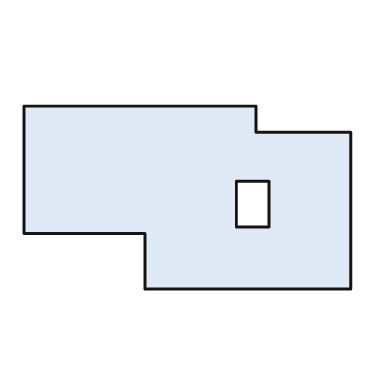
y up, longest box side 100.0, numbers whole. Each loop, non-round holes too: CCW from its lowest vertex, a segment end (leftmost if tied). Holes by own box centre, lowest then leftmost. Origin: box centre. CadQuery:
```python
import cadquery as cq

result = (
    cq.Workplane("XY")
    .moveTo(-13.0, -28.0)
    .lineTo(50.0, -28.0)
    .lineTo(50.0, 20.0)
    .lineTo(21.0, 20.0)
    .lineTo(21.0, 28.0)
    .lineTo(-50.0, 28.0)
    .lineTo(-50.0, -11.0)
    .lineTo(-13.0, -11.0)
    .close()
    .moveTo(15.0, -9.0)
    .lineTo(25.0, -9.0)
    .lineTo(25.0, 5.0)
    .lineTo(15.0, 5.0)
    .close()
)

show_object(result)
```